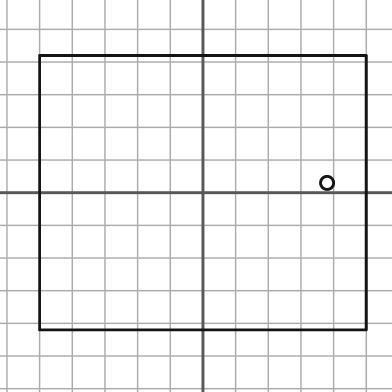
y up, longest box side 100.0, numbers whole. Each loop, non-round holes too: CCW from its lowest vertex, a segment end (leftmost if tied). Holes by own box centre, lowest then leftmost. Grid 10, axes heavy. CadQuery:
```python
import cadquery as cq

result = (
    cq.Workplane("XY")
    .moveTo(-50.0, -42.0)
    .lineTo(50.0, -42.0)
    .lineTo(50.0, 42.0)
    .lineTo(-50.0, 42.0)
    .close()
    .moveTo(38.0, 3.0)
    .circle(2.0)
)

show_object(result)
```